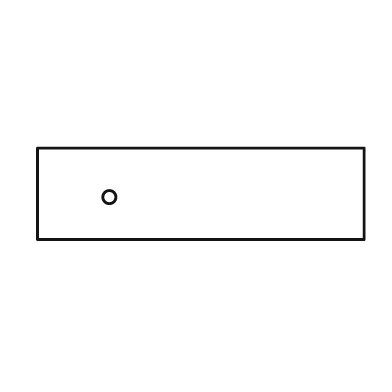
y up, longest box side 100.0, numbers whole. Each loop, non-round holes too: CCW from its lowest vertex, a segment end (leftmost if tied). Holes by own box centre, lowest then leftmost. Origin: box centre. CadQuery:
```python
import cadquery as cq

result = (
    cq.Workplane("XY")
    .moveTo(-50.0, -14.0)
    .lineTo(50.0, -14.0)
    .lineTo(50.0, 14.0)
    .lineTo(-50.0, 14.0)
    .close()
    .moveTo(-28.0, -1.0)
    .circle(2.0)
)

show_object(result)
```